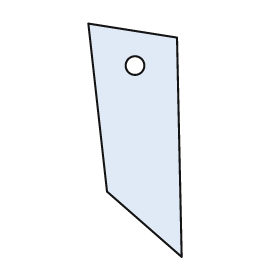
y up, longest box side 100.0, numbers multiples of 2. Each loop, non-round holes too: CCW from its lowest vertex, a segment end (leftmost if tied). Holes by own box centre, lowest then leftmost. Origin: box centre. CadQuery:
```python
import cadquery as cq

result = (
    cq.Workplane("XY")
    .moveTo(20.0, -50.0)
    .lineTo(18.0, 44.0)
    .lineTo(-20.0, 50.0)
    .lineTo(-12.0, -22.0)
    .close()
    .moveTo(0.0, 32.0)
    .circle(4.0)
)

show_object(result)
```